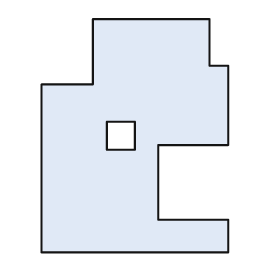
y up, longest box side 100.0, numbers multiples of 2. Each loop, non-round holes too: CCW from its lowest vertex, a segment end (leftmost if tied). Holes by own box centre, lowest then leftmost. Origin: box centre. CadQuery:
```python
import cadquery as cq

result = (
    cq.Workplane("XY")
    .moveTo(-40.0, -50.0)
    .lineTo(40.0, -50.0)
    .lineTo(40.0, -36.0)
    .lineTo(10.0, -36.0)
    .lineTo(10.0, -4.0)
    .lineTo(40.0, -4.0)
    .lineTo(40.0, 30.0)
    .lineTo(32.0, 30.0)
    .lineTo(32.0, 50.0)
    .lineTo(-18.0, 50.0)
    .lineTo(-18.0, 22.0)
    .lineTo(-40.0, 22.0)
    .close()
    .moveTo(-12.0, -6.0)
    .lineTo(0.0, -6.0)
    .lineTo(0.0, 6.0)
    .lineTo(-12.0, 6.0)
    .close()
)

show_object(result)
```